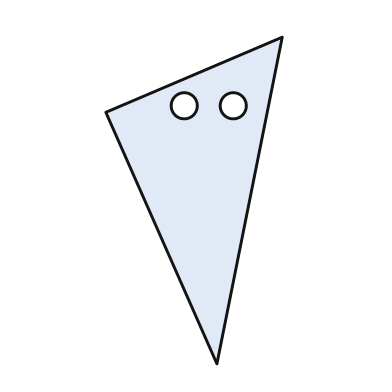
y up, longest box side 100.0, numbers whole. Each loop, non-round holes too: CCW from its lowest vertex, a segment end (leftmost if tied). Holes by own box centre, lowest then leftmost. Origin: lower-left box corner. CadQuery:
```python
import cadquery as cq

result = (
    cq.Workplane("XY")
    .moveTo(34.0, 0.0)
    .lineTo(54.0, 100.0)
    .lineTo(0.0, 77.0)
    .close()
    .moveTo(24.0, 79.0)
    .circle(4.0)
    .moveTo(39.0, 79.0)
    .circle(4.0)
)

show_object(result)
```